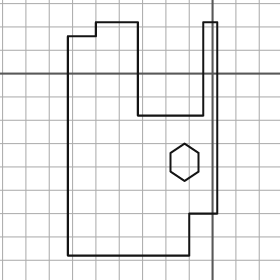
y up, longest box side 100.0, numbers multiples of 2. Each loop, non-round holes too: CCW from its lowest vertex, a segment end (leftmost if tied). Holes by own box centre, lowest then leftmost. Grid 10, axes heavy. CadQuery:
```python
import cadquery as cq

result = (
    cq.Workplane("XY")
    .moveTo(-62.0, -78.0)
    .lineTo(-10.0, -78.0)
    .lineTo(-10.0, -60.0)
    .lineTo(2.0, -60.0)
    .lineTo(2.0, 22.0)
    .lineTo(-4.0, 22.0)
    .lineTo(-4.0, -18.0)
    .lineTo(-32.0, -18.0)
    .lineTo(-32.0, 22.0)
    .lineTo(-50.0, 22.0)
    .lineTo(-50.0, 16.0)
    .lineTo(-62.0, 16.0)
    .close()
    .moveTo(-12.0, -46.0)
    .lineTo(-6.0, -42.0)
    .lineTo(-6.0, -34.0)
    .lineTo(-12.0, -30.0)
    .lineTo(-18.0, -34.0)
    .lineTo(-18.0, -42.0)
    .close()
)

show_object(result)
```